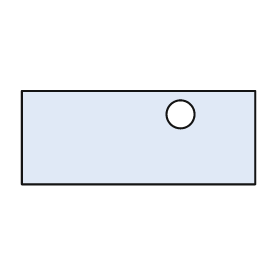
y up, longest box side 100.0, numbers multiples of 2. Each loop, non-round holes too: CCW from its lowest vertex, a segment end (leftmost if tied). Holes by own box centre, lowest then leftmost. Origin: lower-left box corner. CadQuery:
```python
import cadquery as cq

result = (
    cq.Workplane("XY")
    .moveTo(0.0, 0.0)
    .lineTo(100.0, 0.0)
    .lineTo(100.0, 40.0)
    .lineTo(0.0, 40.0)
    .close()
    .moveTo(68.0, 30.0)
    .circle(6.0)
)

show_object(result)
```